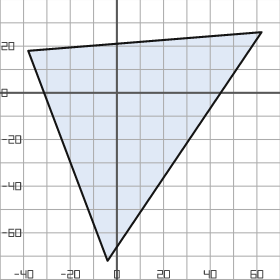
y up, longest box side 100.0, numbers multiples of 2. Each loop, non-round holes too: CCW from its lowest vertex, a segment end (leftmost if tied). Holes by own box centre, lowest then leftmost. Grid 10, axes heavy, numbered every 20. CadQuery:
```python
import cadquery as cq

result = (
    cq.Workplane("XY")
    .moveTo(-4.0, -72.0)
    .lineTo(62.0, 26.0)
    .lineTo(-38.0, 18.0)
    .close()
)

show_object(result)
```